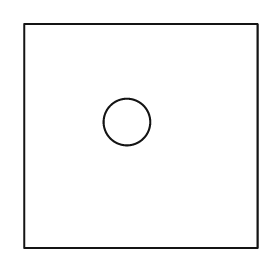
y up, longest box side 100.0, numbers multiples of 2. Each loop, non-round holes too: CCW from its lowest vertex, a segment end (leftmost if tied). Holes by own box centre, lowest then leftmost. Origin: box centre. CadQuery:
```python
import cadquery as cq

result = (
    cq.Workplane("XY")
    .moveTo(-50.0, -48.0)
    .lineTo(50.0, -48.0)
    .lineTo(50.0, 48.0)
    .lineTo(-50.0, 48.0)
    .close()
    .moveTo(-6.0, 6.0)
    .circle(10.0)
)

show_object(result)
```